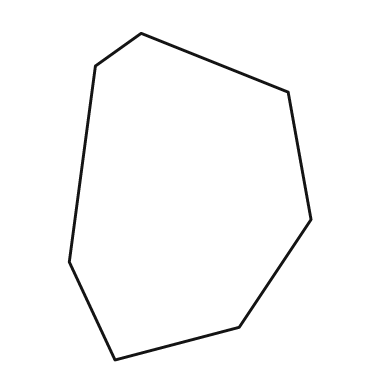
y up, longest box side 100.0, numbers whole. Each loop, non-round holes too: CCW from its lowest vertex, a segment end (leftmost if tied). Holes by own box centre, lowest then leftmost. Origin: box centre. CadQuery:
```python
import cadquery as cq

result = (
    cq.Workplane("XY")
    .moveTo(-23.0, -50.0)
    .lineTo(15.0, -40.0)
    .lineTo(37.0, -7.0)
    .lineTo(30.0, 32.0)
    .lineTo(-15.0, 50.0)
    .lineTo(-29.0, 40.0)
    .lineTo(-37.0, -20.0)
    .close()
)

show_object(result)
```